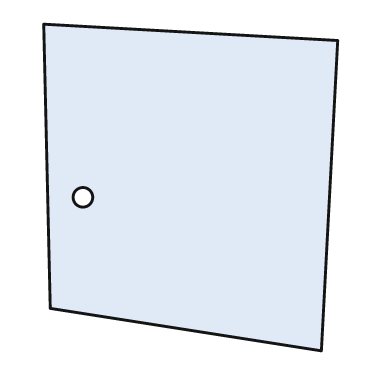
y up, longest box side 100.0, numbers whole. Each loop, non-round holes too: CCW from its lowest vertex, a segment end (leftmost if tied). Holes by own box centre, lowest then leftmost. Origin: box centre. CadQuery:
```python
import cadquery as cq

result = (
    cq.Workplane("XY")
    .moveTo(40.0, -50.0)
    .lineTo(45.0, 45.0)
    .lineTo(-45.0, 50.0)
    .lineTo(-43.0, -37.0)
    .close()
    .moveTo(-33.0, -3.0)
    .circle(3.0)
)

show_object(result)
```